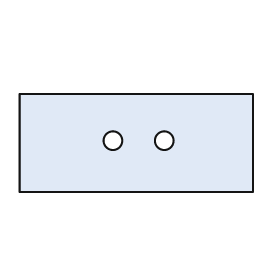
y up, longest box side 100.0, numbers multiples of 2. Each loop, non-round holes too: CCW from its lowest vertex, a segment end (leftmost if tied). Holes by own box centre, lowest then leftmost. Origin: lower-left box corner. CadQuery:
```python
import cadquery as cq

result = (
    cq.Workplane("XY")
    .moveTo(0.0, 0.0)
    .lineTo(100.0, 0.0)
    .lineTo(100.0, 42.0)
    .lineTo(0.0, 42.0)
    .close()
    .moveTo(40.0, 22.0)
    .circle(4.0)
    .moveTo(62.0, 22.0)
    .circle(4.0)
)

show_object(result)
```